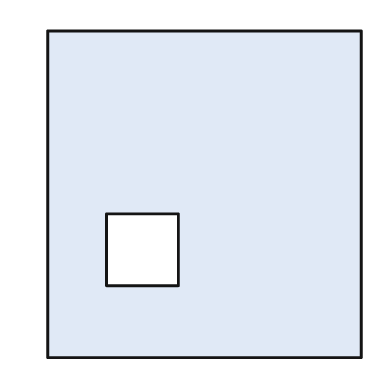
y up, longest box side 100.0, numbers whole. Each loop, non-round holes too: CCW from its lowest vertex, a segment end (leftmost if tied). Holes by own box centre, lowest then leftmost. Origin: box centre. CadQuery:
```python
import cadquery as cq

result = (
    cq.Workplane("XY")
    .moveTo(-48.0, -50.0)
    .lineTo(48.0, -50.0)
    .lineTo(48.0, 50.0)
    .lineTo(-48.0, 50.0)
    .close()
    .moveTo(-30.0, -28.0)
    .lineTo(-8.0, -28.0)
    .lineTo(-8.0, -6.0)
    .lineTo(-30.0, -6.0)
    .close()
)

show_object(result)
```